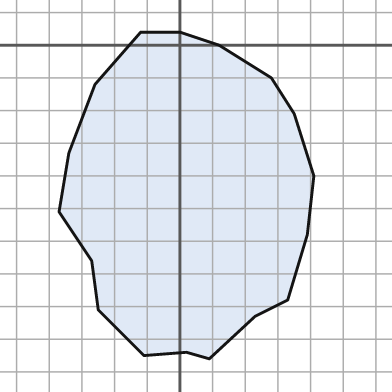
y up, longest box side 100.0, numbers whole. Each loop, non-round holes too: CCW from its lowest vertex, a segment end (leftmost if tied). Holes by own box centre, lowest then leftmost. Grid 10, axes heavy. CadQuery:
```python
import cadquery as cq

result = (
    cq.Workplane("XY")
    .moveTo(9.0, -96.0)
    .lineTo(23.0, -83.0)
    .lineTo(33.0, -78.0)
    .lineTo(39.0, -58.0)
    .lineTo(41.0, -40.0)
    .lineTo(35.0, -21.0)
    .lineTo(28.0, -10.0)
    .lineTo(12.0, 0.0)
    .lineTo(0.0, 4.0)
    .lineTo(-12.0, 4.0)
    .lineTo(-26.0, -12.0)
    .lineTo(-34.0, -33.0)
    .lineTo(-37.0, -51.0)
    .lineTo(-27.0, -66.0)
    .lineTo(-25.0, -81.0)
    .lineTo(-11.0, -95.0)
    .lineTo(2.0, -94.0)
    .close()
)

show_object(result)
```